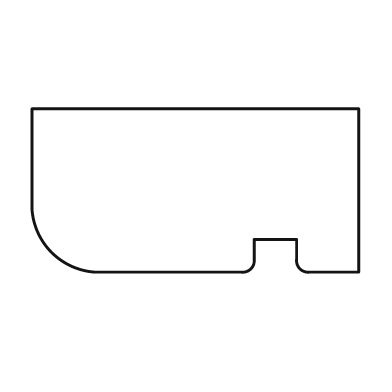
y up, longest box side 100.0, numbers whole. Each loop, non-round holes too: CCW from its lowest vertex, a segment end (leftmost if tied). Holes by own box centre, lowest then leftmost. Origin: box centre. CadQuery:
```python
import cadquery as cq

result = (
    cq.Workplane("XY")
    .moveTo(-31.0, -25.0)
    .lineTo(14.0, -25.0)
    .threePointArc((17.0, -24.0), (18.0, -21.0))
    .lineTo(18.0, -15.0)
    .lineTo(31.0, -15.0)
    .lineTo(31.0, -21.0)
    .threePointArc((32.0, -24.0), (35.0, -25.0))
    .lineTo(50.0, -25.0)
    .lineTo(50.0, 25.0)
    .lineTo(-50.0, 25.0)
    .lineTo(-50.0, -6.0)
    .threePointArc((-44.0, -19.0), (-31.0, -25.0))
    .close()
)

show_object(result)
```